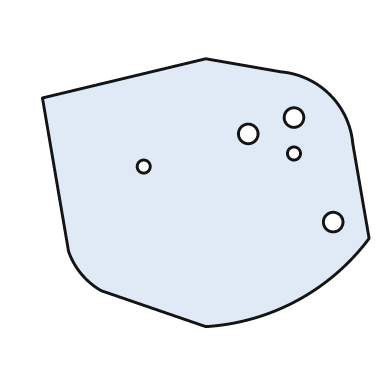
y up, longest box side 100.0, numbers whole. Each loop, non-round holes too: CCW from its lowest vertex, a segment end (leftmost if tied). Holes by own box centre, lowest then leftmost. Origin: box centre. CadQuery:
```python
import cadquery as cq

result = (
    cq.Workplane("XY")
    .moveTo(0.0, -41.0)
    .threePointArc((28.0, -33.0), (50.0, -14.0))
    .lineTo(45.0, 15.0)
    .threePointArc((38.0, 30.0), (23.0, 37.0))
    .lineTo(0.0, 41.0)
    .lineTo(-50.0, 29.0)
    .lineTo(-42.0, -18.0)
    .threePointArc((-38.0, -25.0), (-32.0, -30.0))
    .close()
    .moveTo(39.0, -9.0)
    .circle(3.0)
    .moveTo(-19.0, 8.0)
    .circle(2.0)
    .moveTo(27.0, 12.0)
    .circle(2.0)
    .moveTo(13.0, 18.0)
    .circle(3.0)
    .moveTo(27.0, 23.0)
    .circle(3.0)
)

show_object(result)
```